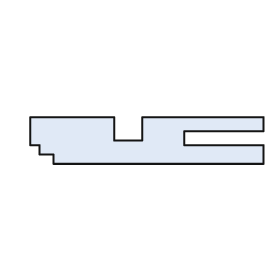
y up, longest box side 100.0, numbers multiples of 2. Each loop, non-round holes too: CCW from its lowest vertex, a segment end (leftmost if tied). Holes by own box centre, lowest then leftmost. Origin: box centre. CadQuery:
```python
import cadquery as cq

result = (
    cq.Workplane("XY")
    .moveTo(-40.0, -10.0)
    .lineTo(50.0, -10.0)
    .lineTo(50.0, -2.0)
    .lineTo(16.0, -2.0)
    .lineTo(16.0, 4.0)
    .lineTo(50.0, 4.0)
    .lineTo(50.0, 10.0)
    .lineTo(-2.0, 10.0)
    .lineTo(-2.0, 0.0)
    .lineTo(-14.0, 0.0)
    .lineTo(-14.0, 10.0)
    .lineTo(-50.0, 10.0)
    .lineTo(-50.0, -2.0)
    .lineTo(-46.0, -2.0)
    .lineTo(-46.0, -6.0)
    .lineTo(-40.0, -6.0)
    .close()
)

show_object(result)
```